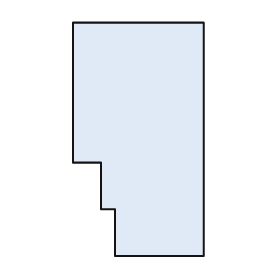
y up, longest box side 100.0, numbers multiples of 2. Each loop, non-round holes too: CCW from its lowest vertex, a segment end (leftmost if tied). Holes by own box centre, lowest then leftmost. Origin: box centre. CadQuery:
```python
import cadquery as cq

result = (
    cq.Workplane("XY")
    .moveTo(-10.0, -50.0)
    .lineTo(28.0, -50.0)
    .lineTo(28.0, 50.0)
    .lineTo(-28.0, 50.0)
    .lineTo(-28.0, -10.0)
    .lineTo(-16.0, -10.0)
    .lineTo(-16.0, -30.0)
    .lineTo(-10.0, -30.0)
    .close()
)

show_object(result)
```